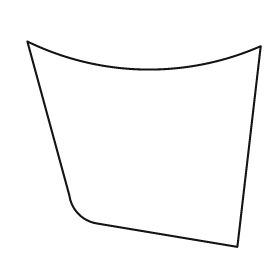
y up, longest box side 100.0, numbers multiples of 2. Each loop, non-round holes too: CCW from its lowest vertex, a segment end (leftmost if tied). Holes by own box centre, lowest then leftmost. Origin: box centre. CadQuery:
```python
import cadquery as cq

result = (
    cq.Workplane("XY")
    .moveTo(40.0, -44.0)
    .lineTo(50.0, 42.0)
    .threePointArc((0.0, 32.0), (-50.0, 44.0))
    .lineTo(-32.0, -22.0)
    .threePointArc((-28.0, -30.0), (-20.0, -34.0))
    .close()
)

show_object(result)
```